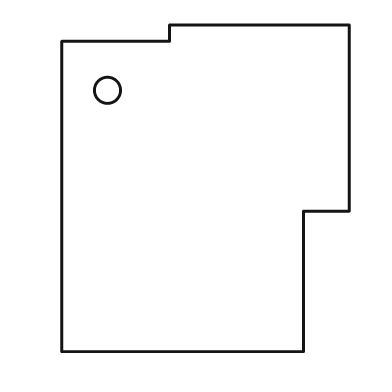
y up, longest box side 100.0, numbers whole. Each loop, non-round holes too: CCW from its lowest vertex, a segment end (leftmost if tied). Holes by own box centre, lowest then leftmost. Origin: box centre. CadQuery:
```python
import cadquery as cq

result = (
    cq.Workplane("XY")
    .moveTo(-44.0, -50.0)
    .lineTo(30.0, -50.0)
    .lineTo(30.0, -7.0)
    .lineTo(44.0, -7.0)
    .lineTo(44.0, 50.0)
    .lineTo(-11.0, 50.0)
    .lineTo(-11.0, 45.0)
    .lineTo(-44.0, 45.0)
    .close()
    .moveTo(-30.0, 30.0)
    .circle(4.0)
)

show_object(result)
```